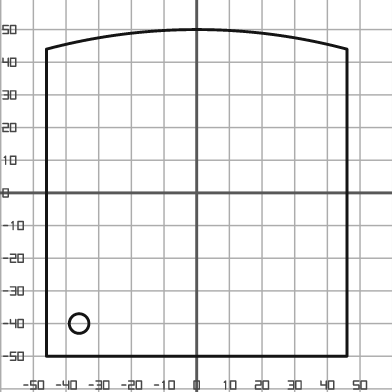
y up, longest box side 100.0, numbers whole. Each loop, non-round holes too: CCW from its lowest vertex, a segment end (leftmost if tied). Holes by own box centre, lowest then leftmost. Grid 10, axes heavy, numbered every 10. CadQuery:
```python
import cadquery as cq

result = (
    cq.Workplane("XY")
    .moveTo(-46.0, -50.0)
    .lineTo(46.0, -50.0)
    .lineTo(46.0, 44.0)
    .threePointArc((0.0, 50.0), (-46.0, 44.0))
    .close()
    .moveTo(-36.0, -40.0)
    .circle(3.0)
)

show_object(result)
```